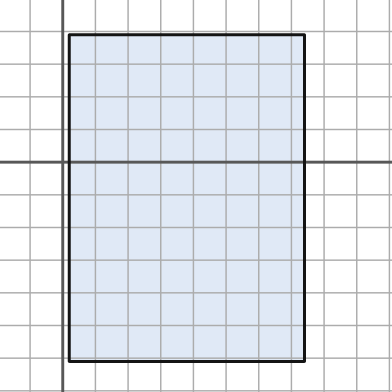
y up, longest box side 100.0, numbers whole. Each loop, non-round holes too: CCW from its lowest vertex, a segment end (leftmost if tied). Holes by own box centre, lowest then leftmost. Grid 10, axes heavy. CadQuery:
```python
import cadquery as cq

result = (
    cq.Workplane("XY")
    .moveTo(2.0, -61.0)
    .lineTo(74.0, -61.0)
    .lineTo(74.0, 39.0)
    .lineTo(2.0, 39.0)
    .close()
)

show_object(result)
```